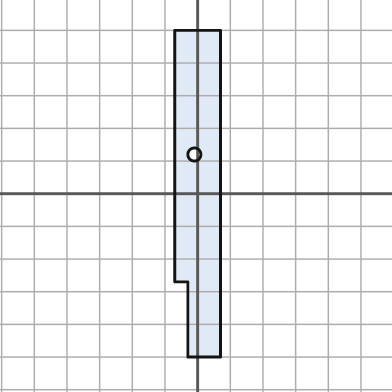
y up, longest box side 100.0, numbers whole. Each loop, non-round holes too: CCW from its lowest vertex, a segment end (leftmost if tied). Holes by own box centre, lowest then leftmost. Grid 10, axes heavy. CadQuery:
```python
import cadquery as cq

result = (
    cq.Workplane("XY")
    .moveTo(-3.0, -50.0)
    .lineTo(7.0, -50.0)
    .lineTo(7.0, 50.0)
    .lineTo(-7.0, 50.0)
    .lineTo(-7.0, -27.0)
    .lineTo(-3.0, -27.0)
    .close()
    .moveTo(-1.0, 12.0)
    .circle(2.0)
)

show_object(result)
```